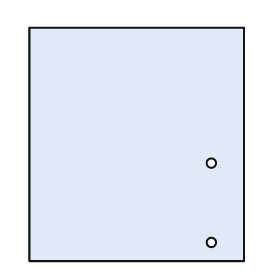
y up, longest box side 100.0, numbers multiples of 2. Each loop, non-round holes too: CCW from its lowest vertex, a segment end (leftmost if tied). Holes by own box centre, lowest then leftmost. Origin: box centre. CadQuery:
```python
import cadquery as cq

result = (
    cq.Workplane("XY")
    .moveTo(-46.0, -50.0)
    .lineTo(46.0, -50.0)
    .lineTo(46.0, 50.0)
    .lineTo(-46.0, 50.0)
    .close()
    .moveTo(32.0, -42.0)
    .circle(2.0)
    .moveTo(32.0, -8.0)
    .circle(2.0)
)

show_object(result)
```